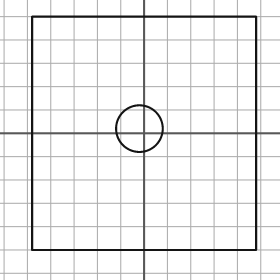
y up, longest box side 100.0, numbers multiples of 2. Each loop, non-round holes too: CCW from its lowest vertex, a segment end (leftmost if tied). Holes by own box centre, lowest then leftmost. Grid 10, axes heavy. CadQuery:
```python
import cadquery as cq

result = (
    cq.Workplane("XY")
    .moveTo(-48.0, -50.0)
    .lineTo(48.0, -50.0)
    .lineTo(48.0, 50.0)
    .lineTo(-48.0, 50.0)
    .close()
    .moveTo(-2.0, 2.0)
    .circle(10.0)
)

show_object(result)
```